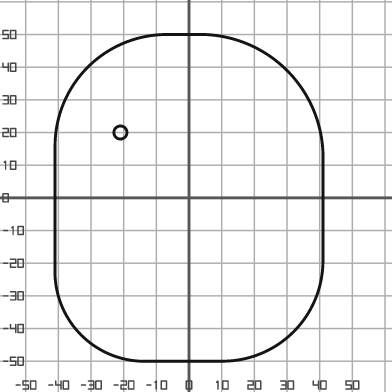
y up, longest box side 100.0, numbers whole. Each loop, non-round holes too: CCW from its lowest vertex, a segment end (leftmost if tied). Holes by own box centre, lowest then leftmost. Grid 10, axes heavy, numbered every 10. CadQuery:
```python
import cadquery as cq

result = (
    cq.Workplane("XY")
    .moveTo(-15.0, -50.0)
    .lineTo(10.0, -50.0)
    .threePointArc((32.0, -41.0), (41.0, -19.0))
    .lineTo(41.0, 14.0)
    .threePointArc((30.0, 39.0), (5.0, 50.0))
    .lineTo(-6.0, 50.0)
    .threePointArc((-31.0, 40.0), (-41.0, 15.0))
    .lineTo(-41.0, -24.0)
    .threePointArc((-33.0, -42.0), (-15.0, -50.0))
    .close()
    .moveTo(-21.0, 20.0)
    .circle(2.0)
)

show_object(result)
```